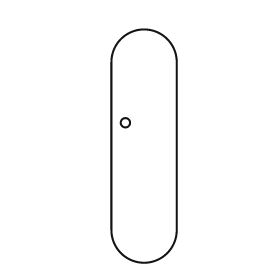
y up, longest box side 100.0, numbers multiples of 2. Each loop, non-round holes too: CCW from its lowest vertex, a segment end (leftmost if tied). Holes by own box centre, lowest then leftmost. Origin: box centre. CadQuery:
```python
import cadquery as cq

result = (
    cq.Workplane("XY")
    .moveTo(-14.0, -36.0)
    .threePointArc((0.0, -50.0), (14.0, -36.0))
    .lineTo(14.0, 36.0)
    .threePointArc((0.0, 50.0), (-14.0, 36.0))
    .close()
    .moveTo(-8.0, 10.0)
    .circle(2.0)
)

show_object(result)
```